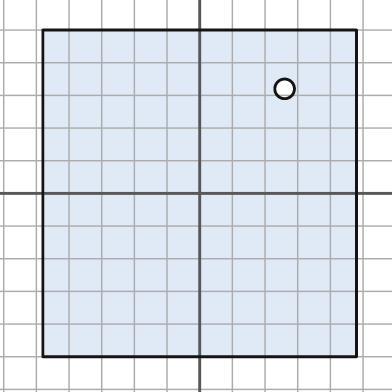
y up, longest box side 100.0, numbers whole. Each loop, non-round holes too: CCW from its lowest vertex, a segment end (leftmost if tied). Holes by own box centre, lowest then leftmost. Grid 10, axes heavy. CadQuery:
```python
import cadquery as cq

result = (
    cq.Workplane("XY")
    .moveTo(-48.0, -50.0)
    .lineTo(48.0, -50.0)
    .lineTo(48.0, 50.0)
    .lineTo(-48.0, 50.0)
    .close()
    .moveTo(26.0, 32.0)
    .circle(3.0)
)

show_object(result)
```